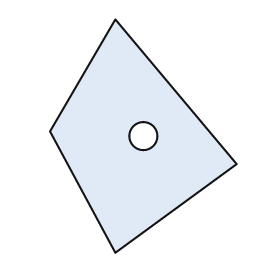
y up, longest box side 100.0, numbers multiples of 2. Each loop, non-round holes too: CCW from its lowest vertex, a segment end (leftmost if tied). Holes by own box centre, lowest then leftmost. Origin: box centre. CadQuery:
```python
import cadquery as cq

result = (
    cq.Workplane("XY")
    .moveTo(-12.0, -50.0)
    .lineTo(40.0, -12.0)
    .lineTo(-12.0, 50.0)
    .lineTo(-40.0, 2.0)
    .close()
    .moveTo(0.0, 0.0)
    .circle(6.0)
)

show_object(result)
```